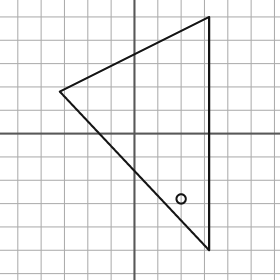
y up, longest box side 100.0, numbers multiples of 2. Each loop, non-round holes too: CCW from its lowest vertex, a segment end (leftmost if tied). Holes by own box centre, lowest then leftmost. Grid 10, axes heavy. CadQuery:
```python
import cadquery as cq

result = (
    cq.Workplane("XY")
    .moveTo(32.0, -50.0)
    .lineTo(32.0, 50.0)
    .lineTo(-32.0, 18.0)
    .close()
    .moveTo(20.0, -28.0)
    .circle(2.0)
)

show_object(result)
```